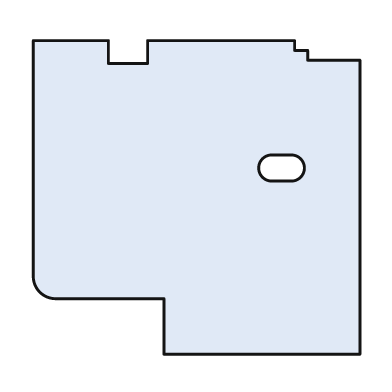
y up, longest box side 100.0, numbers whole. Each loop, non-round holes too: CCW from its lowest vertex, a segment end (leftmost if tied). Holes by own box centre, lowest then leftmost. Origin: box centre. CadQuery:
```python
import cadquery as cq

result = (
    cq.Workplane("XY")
    .moveTo(-10.0, -48.0)
    .lineTo(50.0, -48.0)
    .lineTo(50.0, 42.0)
    .lineTo(34.0, 42.0)
    .lineTo(34.0, 45.0)
    .lineTo(30.0, 45.0)
    .lineTo(30.0, 48.0)
    .lineTo(-15.0, 48.0)
    .lineTo(-15.0, 41.0)
    .lineTo(-27.0, 41.0)
    .lineTo(-27.0, 48.0)
    .lineTo(-50.0, 48.0)
    .lineTo(-50.0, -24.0)
    .threePointArc((-48.0, -29.0), (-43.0, -31.0))
    .lineTo(-10.0, -31.0)
    .close()
    .moveTo(23.0, 5.0)
    .lineTo(29.0, 5.0)
    .threePointArc((33.0, 9.0), (29.0, 13.0))
    .lineTo(23.0, 13.0)
    .threePointArc((19.0, 9.0), (23.0, 5.0))
    .close()
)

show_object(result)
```